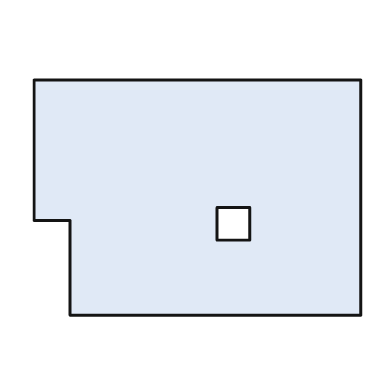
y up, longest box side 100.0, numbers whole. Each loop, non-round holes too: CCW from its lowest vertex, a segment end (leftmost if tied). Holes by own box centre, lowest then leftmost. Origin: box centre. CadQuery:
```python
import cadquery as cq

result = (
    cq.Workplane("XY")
    .moveTo(-39.0, -36.0)
    .lineTo(50.0, -36.0)
    .lineTo(50.0, 36.0)
    .lineTo(-50.0, 36.0)
    .lineTo(-50.0, -7.0)
    .lineTo(-39.0, -7.0)
    .close()
    .moveTo(6.0, -13.0)
    .lineTo(16.0, -13.0)
    .lineTo(16.0, -3.0)
    .lineTo(6.0, -3.0)
    .close()
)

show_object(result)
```